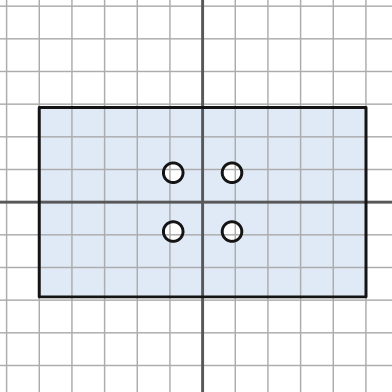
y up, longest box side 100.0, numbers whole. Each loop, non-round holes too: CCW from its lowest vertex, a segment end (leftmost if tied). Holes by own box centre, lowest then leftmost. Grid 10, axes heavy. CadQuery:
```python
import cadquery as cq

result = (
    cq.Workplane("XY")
    .moveTo(-50.0, -29.0)
    .lineTo(50.0, -29.0)
    .lineTo(50.0, 29.0)
    .lineTo(-50.0, 29.0)
    .close()
    .moveTo(-9.0, -9.0)
    .circle(3.0)
    .moveTo(9.0, -9.0)
    .circle(3.0)
    .moveTo(-9.0, 9.0)
    .circle(3.0)
    .moveTo(9.0, 9.0)
    .circle(3.0)
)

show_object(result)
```